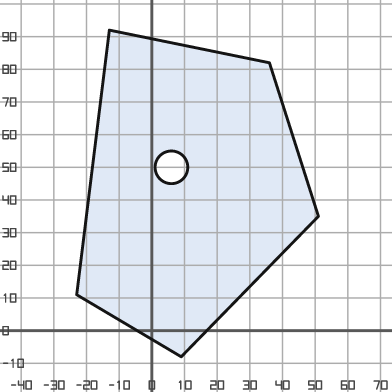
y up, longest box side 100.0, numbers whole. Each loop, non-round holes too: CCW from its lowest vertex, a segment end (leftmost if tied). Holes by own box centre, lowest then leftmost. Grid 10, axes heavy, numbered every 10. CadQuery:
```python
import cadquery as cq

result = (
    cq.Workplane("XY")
    .moveTo(9.0, -8.0)
    .lineTo(51.0, 35.0)
    .lineTo(36.0, 82.0)
    .lineTo(-13.0, 92.0)
    .lineTo(-23.0, 11.0)
    .close()
    .moveTo(6.0, 50.0)
    .circle(5.0)
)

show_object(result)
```